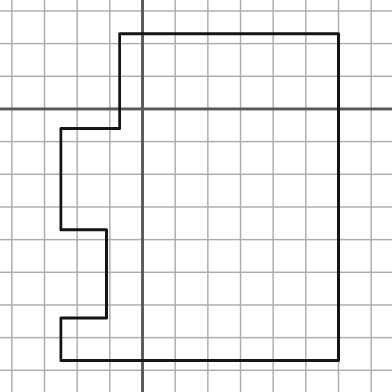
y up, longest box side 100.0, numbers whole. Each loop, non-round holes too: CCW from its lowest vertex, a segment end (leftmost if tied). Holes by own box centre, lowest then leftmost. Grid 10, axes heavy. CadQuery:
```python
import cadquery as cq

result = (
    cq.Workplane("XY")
    .moveTo(-25.0, -77.0)
    .lineTo(60.0, -77.0)
    .lineTo(60.0, 23.0)
    .lineTo(-7.0, 23.0)
    .lineTo(-7.0, -6.0)
    .lineTo(-25.0, -6.0)
    .lineTo(-25.0, -37.0)
    .lineTo(-11.0, -37.0)
    .lineTo(-11.0, -64.0)
    .lineTo(-25.0, -64.0)
    .close()
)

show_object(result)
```